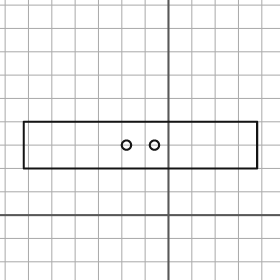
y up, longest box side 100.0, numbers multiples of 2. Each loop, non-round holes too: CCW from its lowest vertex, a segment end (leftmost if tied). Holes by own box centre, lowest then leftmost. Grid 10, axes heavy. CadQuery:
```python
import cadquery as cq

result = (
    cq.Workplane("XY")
    .moveTo(-62.0, 20.0)
    .lineTo(38.0, 20.0)
    .lineTo(38.0, 40.0)
    .lineTo(-62.0, 40.0)
    .close()
    .moveTo(-18.0, 30.0)
    .circle(2.0)
    .moveTo(-6.0, 30.0)
    .circle(2.0)
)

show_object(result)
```